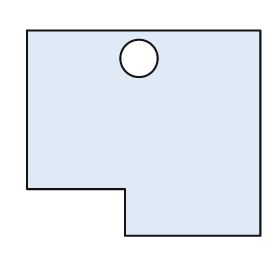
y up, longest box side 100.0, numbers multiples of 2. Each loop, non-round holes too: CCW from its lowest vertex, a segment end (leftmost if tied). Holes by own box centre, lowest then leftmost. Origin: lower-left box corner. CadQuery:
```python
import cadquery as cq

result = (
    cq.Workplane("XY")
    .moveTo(42.0, 0.0)
    .lineTo(100.0, 0.0)
    .lineTo(100.0, 88.0)
    .lineTo(0.0, 88.0)
    .lineTo(0.0, 20.0)
    .lineTo(42.0, 20.0)
    .close()
    .moveTo(48.0, 76.0)
    .circle(8.0)
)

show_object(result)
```